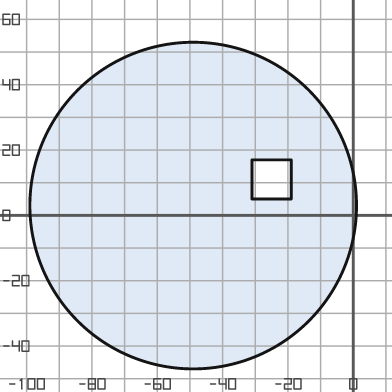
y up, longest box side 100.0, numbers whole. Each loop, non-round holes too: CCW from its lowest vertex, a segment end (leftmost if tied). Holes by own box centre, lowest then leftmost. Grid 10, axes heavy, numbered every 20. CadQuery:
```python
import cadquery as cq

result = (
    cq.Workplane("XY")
    .moveTo(-49.0, 3.0)
    .circle(50.0)
    .moveTo(-31.0, 5.0)
    .lineTo(-19.0, 5.0)
    .lineTo(-19.0, 17.0)
    .lineTo(-31.0, 17.0)
    .close()
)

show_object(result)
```